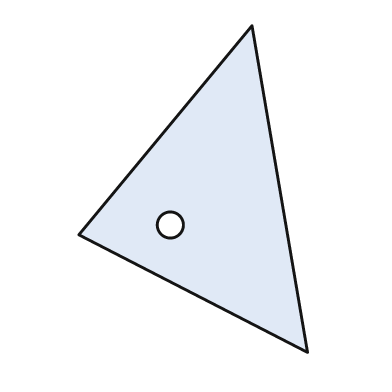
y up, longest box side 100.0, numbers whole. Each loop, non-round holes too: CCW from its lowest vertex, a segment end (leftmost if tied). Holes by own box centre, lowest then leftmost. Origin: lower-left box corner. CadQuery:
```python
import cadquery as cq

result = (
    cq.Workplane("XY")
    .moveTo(70.0, 0.0)
    .lineTo(53.0, 100.0)
    .lineTo(0.0, 36.0)
    .close()
    .moveTo(28.0, 39.0)
    .circle(4.0)
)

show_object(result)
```